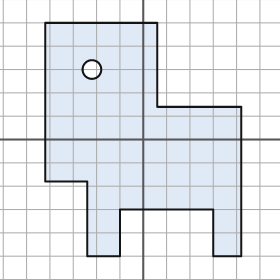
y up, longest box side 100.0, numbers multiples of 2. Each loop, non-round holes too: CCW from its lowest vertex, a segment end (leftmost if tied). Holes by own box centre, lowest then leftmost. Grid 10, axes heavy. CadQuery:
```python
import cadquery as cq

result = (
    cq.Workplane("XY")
    .moveTo(-24.0, -50.0)
    .lineTo(-10.0, -50.0)
    .lineTo(-10.0, -30.0)
    .lineTo(30.0, -30.0)
    .lineTo(30.0, -50.0)
    .lineTo(42.0, -50.0)
    .lineTo(42.0, 14.0)
    .lineTo(6.0, 14.0)
    .lineTo(6.0, 50.0)
    .lineTo(-42.0, 50.0)
    .lineTo(-42.0, -18.0)
    .lineTo(-24.0, -18.0)
    .close()
    .moveTo(-22.0, 30.0)
    .circle(4.0)
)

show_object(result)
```